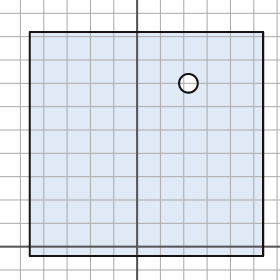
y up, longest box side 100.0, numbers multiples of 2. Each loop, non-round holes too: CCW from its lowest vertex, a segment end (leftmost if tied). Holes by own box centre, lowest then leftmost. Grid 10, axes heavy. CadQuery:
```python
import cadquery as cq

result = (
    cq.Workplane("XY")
    .moveTo(-46.0, -4.0)
    .lineTo(54.0, -4.0)
    .lineTo(54.0, 92.0)
    .lineTo(-46.0, 92.0)
    .close()
    .moveTo(22.0, 70.0)
    .circle(4.0)
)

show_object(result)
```